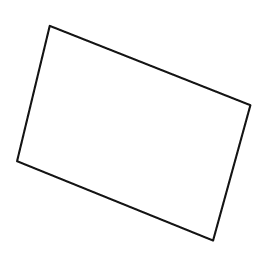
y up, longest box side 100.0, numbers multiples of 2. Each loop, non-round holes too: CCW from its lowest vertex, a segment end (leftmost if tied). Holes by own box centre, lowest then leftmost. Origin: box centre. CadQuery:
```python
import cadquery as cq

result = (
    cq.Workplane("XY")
    .moveTo(34.0, -46.0)
    .lineTo(50.0, 12.0)
    .lineTo(-36.0, 46.0)
    .lineTo(-50.0, -12.0)
    .close()
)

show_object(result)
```